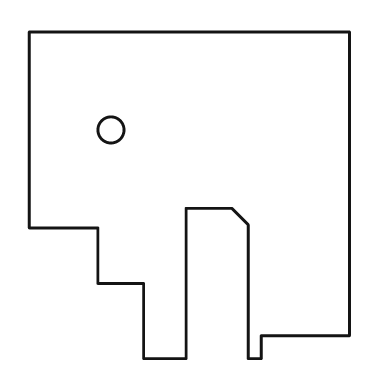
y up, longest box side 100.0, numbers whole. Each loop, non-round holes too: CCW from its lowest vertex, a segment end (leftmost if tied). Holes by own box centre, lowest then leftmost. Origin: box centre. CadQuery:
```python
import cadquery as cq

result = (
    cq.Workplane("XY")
    .moveTo(-14.0, -50.0)
    .lineTo(-1.0, -50.0)
    .lineTo(-1.0, -4.0)
    .lineTo(13.0, -4.0)
    .lineTo(18.0, -9.0)
    .lineTo(18.0, -50.0)
    .lineTo(22.0, -50.0)
    .lineTo(22.0, -43.0)
    .lineTo(49.0, -43.0)
    .lineTo(49.0, 50.0)
    .lineTo(-49.0, 50.0)
    .lineTo(-49.0, -10.0)
    .lineTo(-28.0, -10.0)
    .lineTo(-28.0, -27.0)
    .lineTo(-14.0, -27.0)
    .close()
    .moveTo(-24.0, 20.0)
    .circle(4.0)
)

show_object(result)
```